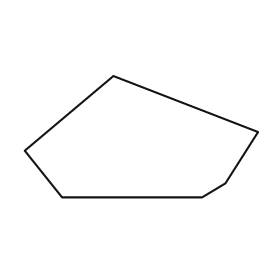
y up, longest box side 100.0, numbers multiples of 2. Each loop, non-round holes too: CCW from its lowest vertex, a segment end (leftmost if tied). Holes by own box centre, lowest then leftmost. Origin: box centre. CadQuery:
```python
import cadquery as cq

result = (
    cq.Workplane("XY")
    .moveTo(-34.0, -26.0)
    .lineTo(26.0, -26.0)
    .lineTo(36.0, -20.0)
    .lineTo(50.0, 2.0)
    .lineTo(-12.0, 26.0)
    .lineTo(-50.0, -6.0)
    .close()
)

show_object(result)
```